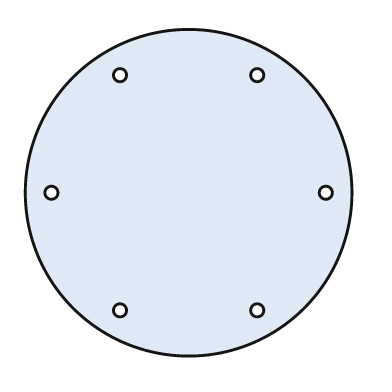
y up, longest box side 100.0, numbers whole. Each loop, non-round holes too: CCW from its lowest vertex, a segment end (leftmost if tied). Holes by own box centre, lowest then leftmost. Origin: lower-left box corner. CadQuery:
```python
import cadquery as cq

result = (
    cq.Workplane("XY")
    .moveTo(50.0, 50.0)
    .circle(50.0)
    .moveTo(29.0, 14.0)
    .circle(2.0)
    .moveTo(71.0, 14.0)
    .circle(2.0)
    .moveTo(8.0, 50.0)
    .circle(2.0)
    .moveTo(92.0, 50.0)
    .circle(2.0)
    .moveTo(29.0, 86.0)
    .circle(2.0)
    .moveTo(71.0, 86.0)
    .circle(2.0)
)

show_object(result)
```